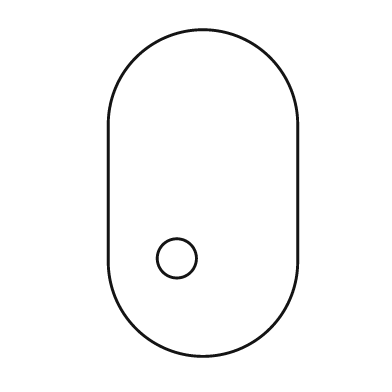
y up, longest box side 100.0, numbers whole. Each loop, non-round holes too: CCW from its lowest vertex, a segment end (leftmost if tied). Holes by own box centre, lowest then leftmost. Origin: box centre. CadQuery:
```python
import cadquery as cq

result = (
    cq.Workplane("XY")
    .moveTo(-29.0, -21.0)
    .threePointArc((0.0, -50.0), (29.0, -21.0))
    .lineTo(29.0, 21.0)
    .threePointArc((0.0, 50.0), (-29.0, 21.0))
    .close()
    .moveTo(-8.0, -20.0)
    .circle(6.0)
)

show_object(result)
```